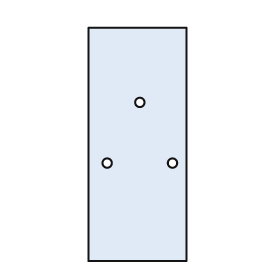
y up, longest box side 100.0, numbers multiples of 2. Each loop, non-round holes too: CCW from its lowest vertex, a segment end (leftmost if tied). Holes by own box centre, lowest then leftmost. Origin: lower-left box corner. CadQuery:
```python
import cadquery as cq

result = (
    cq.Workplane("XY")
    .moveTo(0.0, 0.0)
    .lineTo(42.0, 0.0)
    .lineTo(42.0, 100.0)
    .lineTo(0.0, 100.0)
    .close()
    .moveTo(8.0, 42.0)
    .circle(2.0)
    .moveTo(36.0, 42.0)
    .circle(2.0)
    .moveTo(22.0, 68.0)
    .circle(2.0)
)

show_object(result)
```